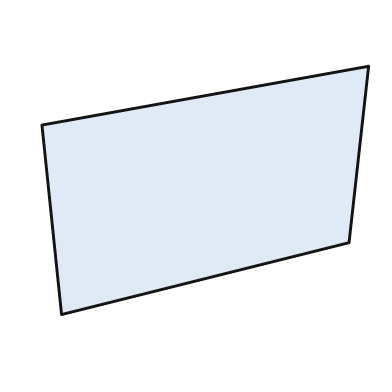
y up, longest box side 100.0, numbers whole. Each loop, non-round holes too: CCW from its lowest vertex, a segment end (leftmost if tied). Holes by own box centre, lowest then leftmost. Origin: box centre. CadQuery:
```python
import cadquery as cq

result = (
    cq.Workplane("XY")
    .moveTo(-44.0, -38.0)
    .lineTo(44.0, -16.0)
    .lineTo(50.0, 38.0)
    .lineTo(-50.0, 20.0)
    .close()
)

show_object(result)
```